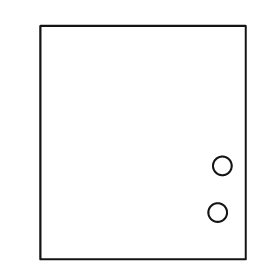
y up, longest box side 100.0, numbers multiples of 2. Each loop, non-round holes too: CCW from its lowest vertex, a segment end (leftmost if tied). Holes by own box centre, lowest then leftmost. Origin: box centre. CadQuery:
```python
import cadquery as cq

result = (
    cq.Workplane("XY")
    .moveTo(-44.0, -50.0)
    .lineTo(44.0, -50.0)
    .lineTo(44.0, 50.0)
    .lineTo(-44.0, 50.0)
    .close()
    .moveTo(32.0, -30.0)
    .circle(4.0)
    .moveTo(34.0, -10.0)
    .circle(4.0)
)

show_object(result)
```